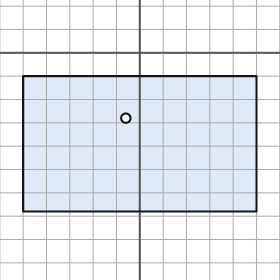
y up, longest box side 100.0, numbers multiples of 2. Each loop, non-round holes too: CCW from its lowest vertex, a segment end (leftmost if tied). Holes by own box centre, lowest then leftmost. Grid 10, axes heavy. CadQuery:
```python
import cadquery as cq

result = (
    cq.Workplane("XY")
    .moveTo(-50.0, -68.0)
    .lineTo(50.0, -68.0)
    .lineTo(50.0, -10.0)
    .lineTo(-50.0, -10.0)
    .close()
    .moveTo(-6.0, -28.0)
    .circle(2.0)
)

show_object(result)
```